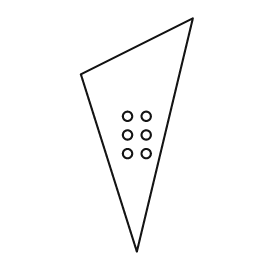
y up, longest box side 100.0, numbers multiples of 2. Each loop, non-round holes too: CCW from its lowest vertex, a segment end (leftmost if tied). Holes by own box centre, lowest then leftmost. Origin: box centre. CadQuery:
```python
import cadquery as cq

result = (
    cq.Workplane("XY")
    .moveTo(0.0, -50.0)
    .lineTo(24.0, 50.0)
    .lineTo(-24.0, 26.0)
    .close()
    .moveTo(-4.0, -8.0)
    .circle(2.0)
    .moveTo(4.0, -8.0)
    .circle(2.0)
    .moveTo(-4.0, 0.0)
    .circle(2.0)
    .moveTo(4.0, 0.0)
    .circle(2.0)
    .moveTo(-4.0, 8.0)
    .circle(2.0)
    .moveTo(4.0, 8.0)
    .circle(2.0)
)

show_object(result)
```